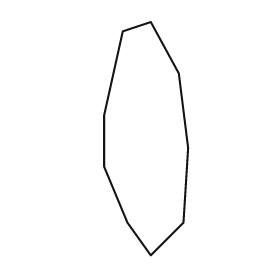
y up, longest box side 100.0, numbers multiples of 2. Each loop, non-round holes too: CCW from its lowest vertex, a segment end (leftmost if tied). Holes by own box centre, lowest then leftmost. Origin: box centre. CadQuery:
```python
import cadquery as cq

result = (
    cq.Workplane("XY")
    .moveTo(2.0, -50.0)
    .lineTo(16.0, -36.0)
    .lineTo(18.0, -4.0)
    .lineTo(14.0, 28.0)
    .lineTo(2.0, 50.0)
    .lineTo(-10.0, 46.0)
    .lineTo(-18.0, 10.0)
    .lineTo(-18.0, -12.0)
    .lineTo(-8.0, -36.0)
    .close()
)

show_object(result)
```